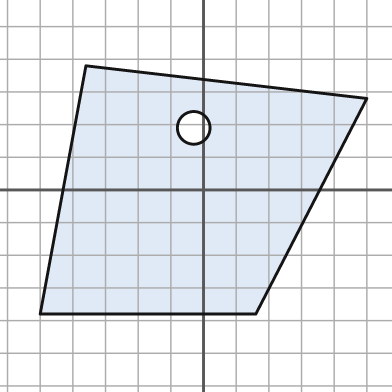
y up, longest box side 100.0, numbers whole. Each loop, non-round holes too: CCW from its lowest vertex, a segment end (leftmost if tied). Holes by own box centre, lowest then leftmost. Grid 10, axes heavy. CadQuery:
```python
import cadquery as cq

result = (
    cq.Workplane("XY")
    .moveTo(-50.0, -38.0)
    .lineTo(16.0, -38.0)
    .lineTo(50.0, 28.0)
    .lineTo(-36.0, 38.0)
    .close()
    .moveTo(-3.0, 19.0)
    .circle(5.0)
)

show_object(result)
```